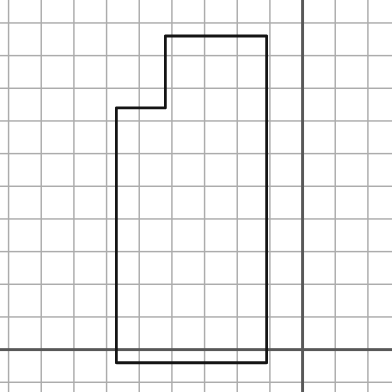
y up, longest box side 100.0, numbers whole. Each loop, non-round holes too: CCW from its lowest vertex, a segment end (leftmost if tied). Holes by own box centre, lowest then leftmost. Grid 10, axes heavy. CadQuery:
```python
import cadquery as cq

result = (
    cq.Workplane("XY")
    .moveTo(-57.0, -4.0)
    .lineTo(-11.0, -4.0)
    .lineTo(-11.0, 96.0)
    .lineTo(-42.0, 96.0)
    .lineTo(-42.0, 74.0)
    .lineTo(-57.0, 74.0)
    .close()
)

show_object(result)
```